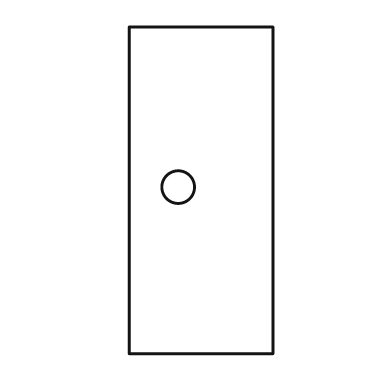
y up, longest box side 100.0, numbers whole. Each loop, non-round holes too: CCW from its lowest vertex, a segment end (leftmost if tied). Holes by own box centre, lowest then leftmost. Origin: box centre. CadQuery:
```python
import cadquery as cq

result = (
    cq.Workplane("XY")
    .moveTo(-22.0, -50.0)
    .lineTo(22.0, -50.0)
    .lineTo(22.0, 50.0)
    .lineTo(-22.0, 50.0)
    .close()
    .moveTo(-7.0, 1.0)
    .circle(5.0)
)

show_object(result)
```